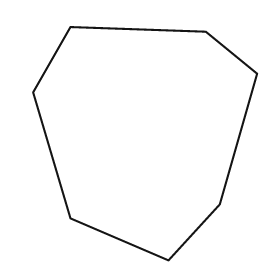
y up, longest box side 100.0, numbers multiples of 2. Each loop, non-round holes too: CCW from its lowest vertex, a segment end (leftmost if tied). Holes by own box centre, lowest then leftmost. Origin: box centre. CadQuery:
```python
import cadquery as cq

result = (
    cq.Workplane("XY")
    .moveTo(10.0, -50.0)
    .lineTo(32.0, -26.0)
    .lineTo(48.0, 30.0)
    .lineTo(26.0, 48.0)
    .lineTo(-32.0, 50.0)
    .lineTo(-48.0, 22.0)
    .lineTo(-32.0, -32.0)
    .close()
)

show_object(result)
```